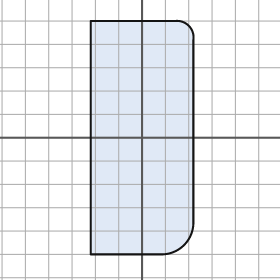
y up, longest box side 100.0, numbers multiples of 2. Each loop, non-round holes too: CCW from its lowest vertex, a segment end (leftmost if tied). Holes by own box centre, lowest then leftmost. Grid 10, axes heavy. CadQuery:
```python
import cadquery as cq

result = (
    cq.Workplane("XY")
    .moveTo(-22.0, -50.0)
    .lineTo(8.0, -50.0)
    .threePointArc((18.0, -46.0), (22.0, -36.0))
    .lineTo(22.0, 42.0)
    .threePointArc((20.0, 48.0), (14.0, 50.0))
    .lineTo(-22.0, 50.0)
    .close()
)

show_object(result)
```